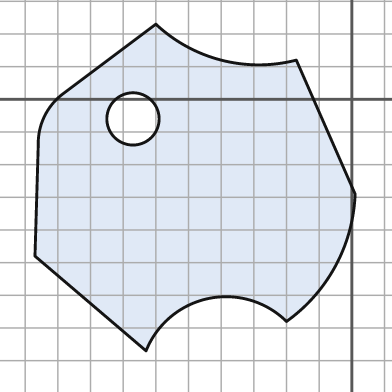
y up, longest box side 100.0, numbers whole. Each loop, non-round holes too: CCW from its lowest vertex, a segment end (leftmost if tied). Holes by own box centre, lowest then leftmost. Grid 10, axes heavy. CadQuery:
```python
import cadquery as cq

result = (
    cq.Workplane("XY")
    .moveTo(-63.0, -77.0)
    .threePointArc((-44.0, -61.0), (-20.0, -68.0))
    .threePointArc((-5.0, -51.0), (1.0, -29.0))
    .lineTo(-17.0, 12.0)
    .threePointArc((-40.0, 12.0), (-60.0, 23.0))
    .lineTo(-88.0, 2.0)
    .threePointArc((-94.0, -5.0), (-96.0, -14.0))
    .lineTo(-97.0, -48.0)
    .close()
    .moveTo(-67.0, -6.0)
    .circle(8.0)
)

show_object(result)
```